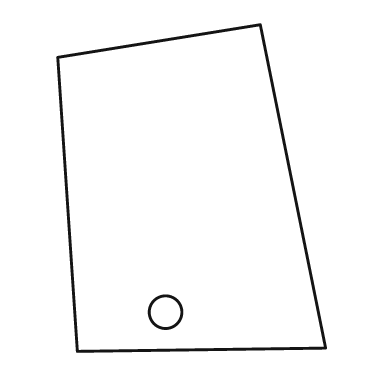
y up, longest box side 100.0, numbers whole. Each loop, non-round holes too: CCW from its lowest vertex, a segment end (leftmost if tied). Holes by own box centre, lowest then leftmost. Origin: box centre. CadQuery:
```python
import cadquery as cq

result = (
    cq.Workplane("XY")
    .moveTo(-35.0, -50.0)
    .lineTo(41.0, -49.0)
    .lineTo(21.0, 50.0)
    .lineTo(-41.0, 40.0)
    .close()
    .moveTo(-8.0, -38.0)
    .circle(5.0)
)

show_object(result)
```